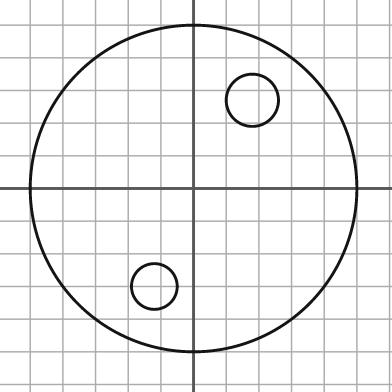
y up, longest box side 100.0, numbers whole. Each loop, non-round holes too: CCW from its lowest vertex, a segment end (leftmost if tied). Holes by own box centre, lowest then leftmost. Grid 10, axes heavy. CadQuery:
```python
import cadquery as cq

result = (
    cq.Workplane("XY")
    .moveTo(0.0, 0.0)
    .circle(50.0)
    .moveTo(-12.0, -30.0)
    .circle(7.0)
    .moveTo(18.0, 27.0)
    .circle(8.0)
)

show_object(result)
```